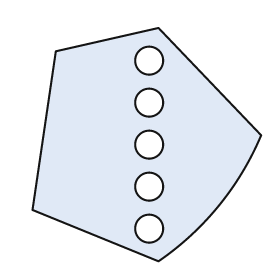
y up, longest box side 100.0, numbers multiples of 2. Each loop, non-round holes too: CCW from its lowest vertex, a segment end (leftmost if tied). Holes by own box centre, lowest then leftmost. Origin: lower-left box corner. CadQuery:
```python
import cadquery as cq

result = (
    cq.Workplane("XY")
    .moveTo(54.0, 0.0)
    .threePointArc((80.0, 24.0), (98.0, 54.0))
    .lineTo(54.0, 100.0)
    .lineTo(10.0, 90.0)
    .lineTo(0.0, 22.0)
    .close()
    .moveTo(50.0, 14.0)
    .circle(6.0)
    .moveTo(50.0, 32.0)
    .circle(6.0)
    .moveTo(50.0, 50.0)
    .circle(6.0)
    .moveTo(50.0, 68.0)
    .circle(6.0)
    .moveTo(50.0, 86.0)
    .circle(6.0)
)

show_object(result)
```